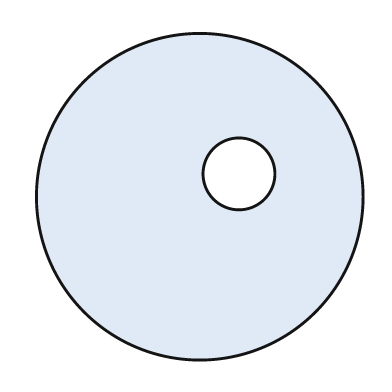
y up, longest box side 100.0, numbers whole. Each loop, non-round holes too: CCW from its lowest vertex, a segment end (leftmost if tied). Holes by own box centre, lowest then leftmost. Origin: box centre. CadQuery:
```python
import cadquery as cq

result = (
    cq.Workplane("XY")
    .moveTo(0.0, 0.0)
    .circle(50.0)
    .moveTo(12.0, 7.0)
    .circle(11.0)
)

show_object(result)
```